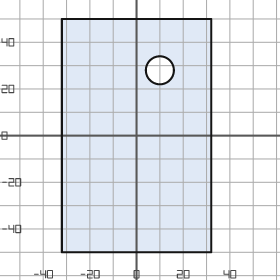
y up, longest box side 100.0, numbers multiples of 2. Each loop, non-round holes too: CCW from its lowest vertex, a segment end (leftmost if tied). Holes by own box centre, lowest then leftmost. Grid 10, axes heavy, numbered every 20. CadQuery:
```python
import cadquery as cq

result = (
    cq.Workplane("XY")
    .moveTo(-32.0, -50.0)
    .lineTo(32.0, -50.0)
    .lineTo(32.0, 50.0)
    .lineTo(-32.0, 50.0)
    .close()
    .moveTo(10.0, 28.0)
    .circle(6.0)
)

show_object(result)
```